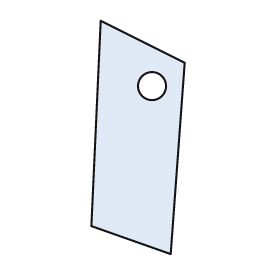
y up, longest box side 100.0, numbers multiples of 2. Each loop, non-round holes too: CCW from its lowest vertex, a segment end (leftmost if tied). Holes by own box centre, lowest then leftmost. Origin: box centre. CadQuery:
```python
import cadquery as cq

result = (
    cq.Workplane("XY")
    .moveTo(14.0, -50.0)
    .lineTo(20.0, 32.0)
    .lineTo(-16.0, 50.0)
    .lineTo(-20.0, -38.0)
    .close()
    .moveTo(6.0, 22.0)
    .circle(6.0)
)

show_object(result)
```